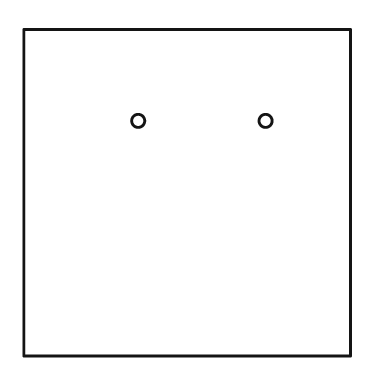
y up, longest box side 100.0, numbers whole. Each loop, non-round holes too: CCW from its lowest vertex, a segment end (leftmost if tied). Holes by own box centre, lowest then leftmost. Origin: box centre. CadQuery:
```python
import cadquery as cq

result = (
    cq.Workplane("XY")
    .moveTo(-50.0, -50.0)
    .lineTo(50.0, -50.0)
    .lineTo(50.0, 50.0)
    .lineTo(-50.0, 50.0)
    .close()
    .moveTo(-15.0, 22.0)
    .circle(2.0)
    .moveTo(24.0, 22.0)
    .circle(2.0)
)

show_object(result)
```